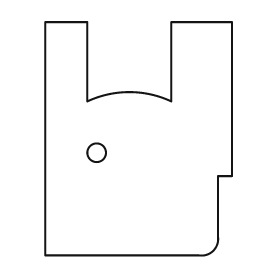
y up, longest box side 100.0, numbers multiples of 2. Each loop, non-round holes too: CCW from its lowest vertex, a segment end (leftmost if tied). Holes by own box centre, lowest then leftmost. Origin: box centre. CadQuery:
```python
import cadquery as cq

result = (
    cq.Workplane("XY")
    .moveTo(-40.0, -50.0)
    .lineTo(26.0, -50.0)
    .threePointArc((32.0, -48.0), (34.0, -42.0))
    .lineTo(34.0, -16.0)
    .lineTo(40.0, -16.0)
    .lineTo(40.0, 50.0)
    .lineTo(14.0, 50.0)
    .lineTo(14.0, 16.0)
    .threePointArc((-4.0, 20.0), (-22.0, 16.0))
    .lineTo(-22.0, 50.0)
    .lineTo(-40.0, 50.0)
    .close()
    .moveTo(-18.0, -6.0)
    .circle(4.0)
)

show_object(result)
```